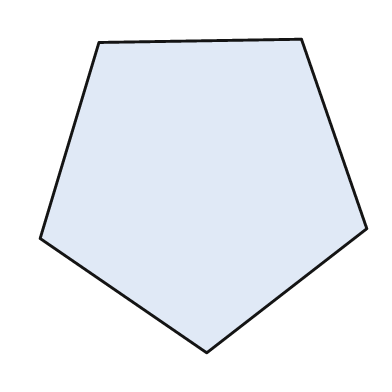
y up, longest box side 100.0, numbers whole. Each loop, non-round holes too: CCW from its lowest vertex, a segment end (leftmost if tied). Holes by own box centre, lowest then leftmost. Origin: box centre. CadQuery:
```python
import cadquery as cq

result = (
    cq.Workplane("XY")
    .moveTo(1.0, -48.0)
    .lineTo(50.0, -10.0)
    .lineTo(30.0, 48.0)
    .lineTo(-32.0, 47.0)
    .lineTo(-50.0, -13.0)
    .close()
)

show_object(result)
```